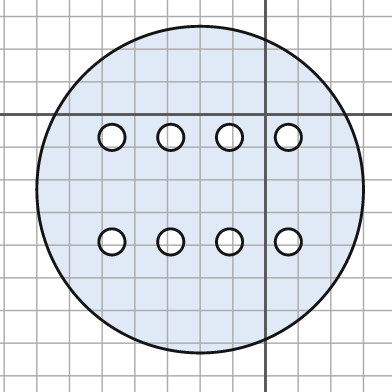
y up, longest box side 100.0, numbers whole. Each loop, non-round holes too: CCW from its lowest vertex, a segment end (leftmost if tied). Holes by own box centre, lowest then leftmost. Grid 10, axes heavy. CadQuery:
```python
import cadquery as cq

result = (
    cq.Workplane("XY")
    .moveTo(-20.0, -23.0)
    .circle(50.0)
    .moveTo(-47.0, -39.0)
    .circle(4.0)
    .moveTo(-29.0, -39.0)
    .circle(4.0)
    .moveTo(-11.0, -39.0)
    .circle(4.0)
    .moveTo(7.0, -39.0)
    .circle(4.0)
    .moveTo(-47.0, -7.0)
    .circle(4.0)
    .moveTo(-29.0, -7.0)
    .circle(4.0)
    .moveTo(-11.0, -7.0)
    .circle(4.0)
    .moveTo(7.0, -7.0)
    .circle(4.0)
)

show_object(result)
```